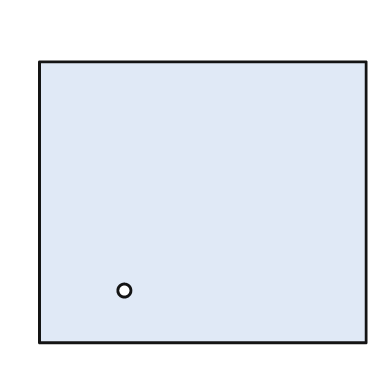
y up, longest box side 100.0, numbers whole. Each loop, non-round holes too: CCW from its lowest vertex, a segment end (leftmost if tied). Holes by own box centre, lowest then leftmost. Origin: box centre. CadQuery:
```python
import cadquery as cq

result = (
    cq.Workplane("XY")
    .moveTo(-50.0, -43.0)
    .lineTo(50.0, -43.0)
    .lineTo(50.0, 43.0)
    .lineTo(-50.0, 43.0)
    .close()
    .moveTo(-24.0, -27.0)
    .circle(2.0)
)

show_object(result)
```